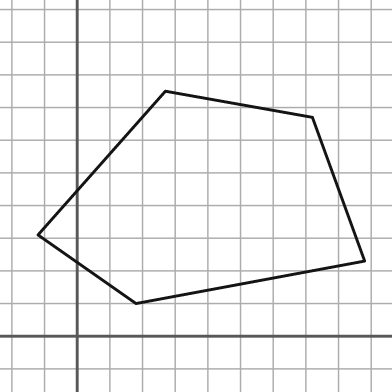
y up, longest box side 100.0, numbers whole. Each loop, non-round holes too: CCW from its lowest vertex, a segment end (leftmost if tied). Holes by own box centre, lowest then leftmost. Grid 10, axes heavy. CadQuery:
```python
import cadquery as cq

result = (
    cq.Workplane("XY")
    .moveTo(18.0, 10.0)
    .lineTo(88.0, 23.0)
    .lineTo(72.0, 67.0)
    .lineTo(27.0, 75.0)
    .lineTo(-12.0, 31.0)
    .close()
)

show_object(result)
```